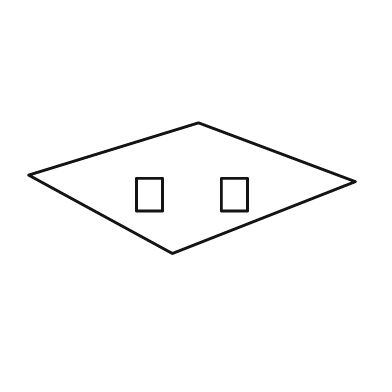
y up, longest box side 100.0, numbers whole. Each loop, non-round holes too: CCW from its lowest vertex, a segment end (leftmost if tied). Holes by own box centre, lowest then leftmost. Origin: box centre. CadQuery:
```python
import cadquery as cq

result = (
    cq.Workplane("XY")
    .moveTo(-6.0, -20.0)
    .lineTo(50.0, 2.0)
    .lineTo(2.0, 20.0)
    .lineTo(-50.0, 4.0)
    .close()
    .moveTo(-17.0, -7.0)
    .lineTo(-9.0, -7.0)
    .lineTo(-9.0, 3.0)
    .lineTo(-17.0, 3.0)
    .close()
    .moveTo(9.0, -7.0)
    .lineTo(17.0, -7.0)
    .lineTo(17.0, 3.0)
    .lineTo(9.0, 3.0)
    .close()
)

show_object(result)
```